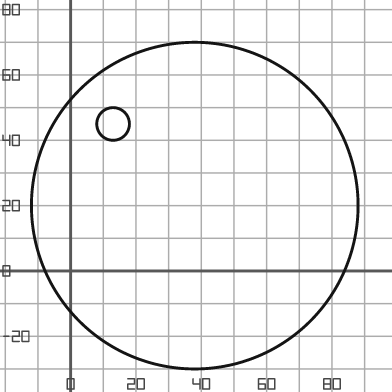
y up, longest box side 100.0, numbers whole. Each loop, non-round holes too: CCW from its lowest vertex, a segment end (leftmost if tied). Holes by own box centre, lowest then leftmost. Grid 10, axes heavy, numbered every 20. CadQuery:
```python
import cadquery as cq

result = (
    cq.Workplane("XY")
    .moveTo(38.0, 20.0)
    .circle(50.0)
    .moveTo(13.0, 45.0)
    .circle(5.0)
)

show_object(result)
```